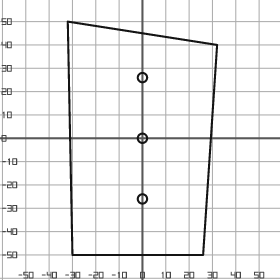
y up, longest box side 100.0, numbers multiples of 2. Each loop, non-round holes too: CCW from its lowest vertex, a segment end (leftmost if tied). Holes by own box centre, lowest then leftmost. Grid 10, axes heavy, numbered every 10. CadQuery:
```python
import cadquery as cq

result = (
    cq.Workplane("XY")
    .moveTo(-30.0, -50.0)
    .lineTo(26.0, -50.0)
    .lineTo(32.0, 40.0)
    .lineTo(-32.0, 50.0)
    .close()
    .moveTo(0.0, -26.0)
    .circle(2.0)
    .moveTo(0.0, 0.0)
    .circle(2.0)
    .moveTo(0.0, 26.0)
    .circle(2.0)
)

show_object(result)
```